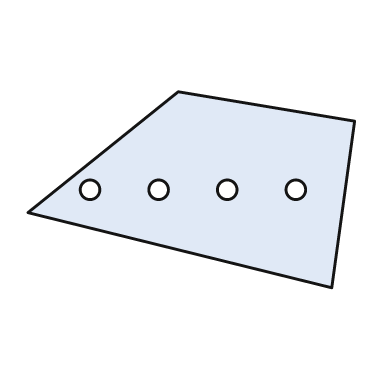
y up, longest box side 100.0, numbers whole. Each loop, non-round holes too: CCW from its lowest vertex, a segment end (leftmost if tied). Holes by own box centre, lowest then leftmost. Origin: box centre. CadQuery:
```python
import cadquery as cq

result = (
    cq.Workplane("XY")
    .moveTo(43.0, -30.0)
    .lineTo(50.0, 21.0)
    .lineTo(-4.0, 30.0)
    .lineTo(-50.0, -7.0)
    .close()
    .moveTo(-31.0, 0.0)
    .circle(3.0)
    .moveTo(-10.0, 0.0)
    .circle(3.0)
    .moveTo(11.0, 0.0)
    .circle(3.0)
    .moveTo(32.0, 0.0)
    .circle(3.0)
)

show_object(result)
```